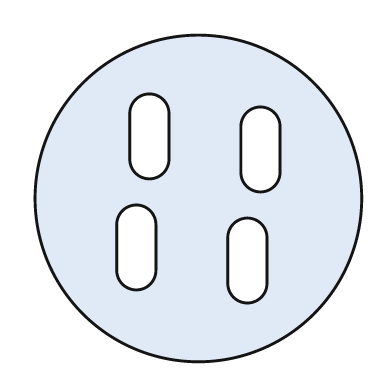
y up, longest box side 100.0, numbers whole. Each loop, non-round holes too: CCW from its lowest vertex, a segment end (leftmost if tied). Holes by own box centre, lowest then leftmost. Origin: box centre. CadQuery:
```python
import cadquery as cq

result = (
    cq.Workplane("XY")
    .moveTo(0.0, 0.0)
    .circle(50.0)
    .moveTo(9.0, -26.0)
    .threePointArc((15.0, -32.0), (21.0, -26.0))
    .lineTo(21.0, -12.0)
    .threePointArc((15.0, -6.0), (9.0, -12.0))
    .close()
    .moveTo(-25.0, -22.0)
    .threePointArc((-19.0, -28.0), (-13.0, -22.0))
    .lineTo(-13.0, -8.0)
    .threePointArc((-19.0, -2.0), (-25.0, -8.0))
    .close()
    .moveTo(13.0, 8.0)
    .threePointArc((19.0, 2.0), (25.0, 8.0))
    .lineTo(25.0, 22.0)
    .threePointArc((19.0, 28.0), (13.0, 22.0))
    .close()
    .moveTo(-21.0, 12.0)
    .threePointArc((-15.0, 6.0), (-9.0, 12.0))
    .lineTo(-9.0, 26.0)
    .threePointArc((-15.0, 32.0), (-21.0, 26.0))
    .close()
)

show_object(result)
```